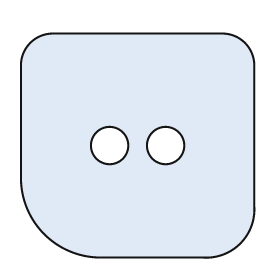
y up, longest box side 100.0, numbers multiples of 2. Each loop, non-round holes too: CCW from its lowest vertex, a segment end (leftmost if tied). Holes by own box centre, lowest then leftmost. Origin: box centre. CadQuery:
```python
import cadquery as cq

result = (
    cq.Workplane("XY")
    .moveTo(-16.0, -48.0)
    .lineTo(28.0, -48.0)
    .threePointArc((44.0, -42.0), (50.0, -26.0))
    .lineTo(50.0, 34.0)
    .threePointArc((46.0, 44.0), (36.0, 48.0))
    .lineTo(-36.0, 48.0)
    .threePointArc((-46.0, 44.0), (-50.0, 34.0))
    .lineTo(-50.0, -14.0)
    .threePointArc((-40.0, -38.0), (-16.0, -48.0))
    .close()
    .moveTo(-12.0, 0.0)
    .circle(8.0)
    .moveTo(12.0, 0.0)
    .circle(8.0)
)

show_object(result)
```